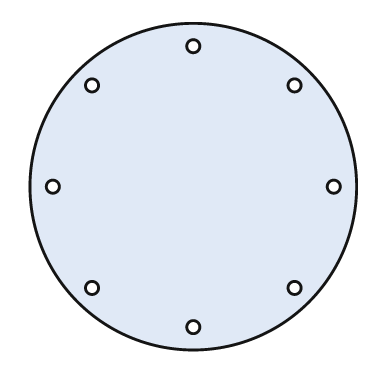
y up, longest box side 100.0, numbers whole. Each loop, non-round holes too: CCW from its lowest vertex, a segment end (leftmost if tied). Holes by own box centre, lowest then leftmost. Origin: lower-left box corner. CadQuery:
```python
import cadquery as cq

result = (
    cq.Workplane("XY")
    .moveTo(50.0, 50.0)
    .circle(50.0)
    .moveTo(50.0, 7.0)
    .circle(2.0)
    .moveTo(19.0, 19.0)
    .circle(2.0)
    .moveTo(81.0, 19.0)
    .circle(2.0)
    .moveTo(7.0, 50.0)
    .circle(2.0)
    .moveTo(93.0, 50.0)
    .circle(2.0)
    .moveTo(19.0, 81.0)
    .circle(2.0)
    .moveTo(81.0, 81.0)
    .circle(2.0)
    .moveTo(50.0, 93.0)
    .circle(2.0)
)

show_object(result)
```